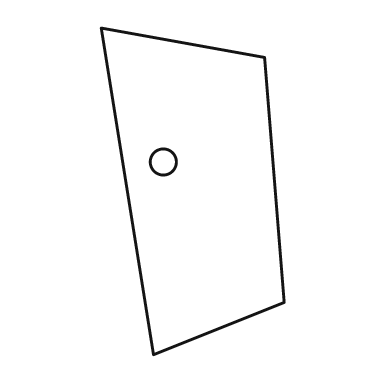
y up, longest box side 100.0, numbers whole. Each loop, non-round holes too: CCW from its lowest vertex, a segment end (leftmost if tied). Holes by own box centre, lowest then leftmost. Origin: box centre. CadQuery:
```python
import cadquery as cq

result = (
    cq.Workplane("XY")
    .moveTo(-12.0, -50.0)
    .lineTo(28.0, -34.0)
    .lineTo(22.0, 41.0)
    .lineTo(-28.0, 50.0)
    .close()
    .moveTo(-9.0, 9.0)
    .circle(4.0)
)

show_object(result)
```